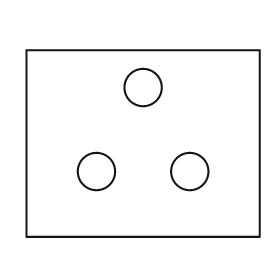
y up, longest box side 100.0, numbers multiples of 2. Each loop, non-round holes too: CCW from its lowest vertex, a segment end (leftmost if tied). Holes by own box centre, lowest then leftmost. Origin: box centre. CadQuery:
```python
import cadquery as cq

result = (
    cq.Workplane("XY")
    .moveTo(-50.0, -40.0)
    .lineTo(50.0, -40.0)
    .lineTo(50.0, 40.0)
    .lineTo(-50.0, 40.0)
    .close()
    .moveTo(-20.0, -12.0)
    .circle(8.0)
    .moveTo(20.0, -12.0)
    .circle(8.0)
    .moveTo(0.0, 24.0)
    .circle(8.0)
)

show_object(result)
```